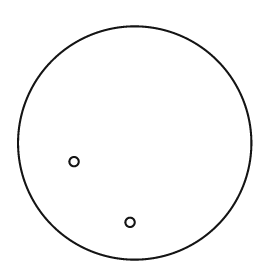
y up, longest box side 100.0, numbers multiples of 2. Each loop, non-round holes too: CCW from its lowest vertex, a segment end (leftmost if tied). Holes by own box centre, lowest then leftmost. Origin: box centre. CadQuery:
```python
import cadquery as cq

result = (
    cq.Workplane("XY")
    .moveTo(0.0, 0.0)
    .circle(50.0)
    .moveTo(-2.0, -34.0)
    .circle(2.0)
    .moveTo(-26.0, -8.0)
    .circle(2.0)
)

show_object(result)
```